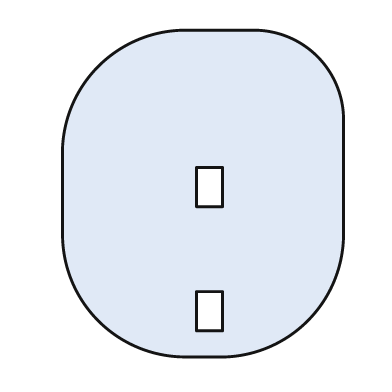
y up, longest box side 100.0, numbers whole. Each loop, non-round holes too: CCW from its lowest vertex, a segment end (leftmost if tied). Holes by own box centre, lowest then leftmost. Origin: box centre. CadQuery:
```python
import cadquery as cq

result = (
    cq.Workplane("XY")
    .moveTo(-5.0, -50.0)
    .lineTo(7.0, -50.0)
    .threePointArc((32.0, -39.0), (43.0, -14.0))
    .lineTo(43.0, 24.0)
    .threePointArc((35.0, 42.0), (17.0, 50.0))
    .lineTo(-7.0, 50.0)
    .threePointArc((-32.0, 39.0), (-43.0, 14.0))
    .lineTo(-43.0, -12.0)
    .threePointArc((-32.0, -39.0), (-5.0, -50.0))
    .close()
    .moveTo(-2.0, -42.0)
    .lineTo(6.0, -42.0)
    .lineTo(6.0, -30.0)
    .lineTo(-2.0, -30.0)
    .close()
    .moveTo(-2.0, -4.0)
    .lineTo(6.0, -4.0)
    .lineTo(6.0, 8.0)
    .lineTo(-2.0, 8.0)
    .close()
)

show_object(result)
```